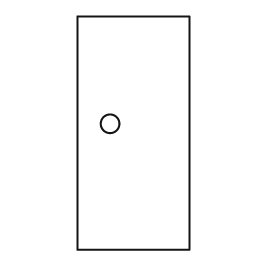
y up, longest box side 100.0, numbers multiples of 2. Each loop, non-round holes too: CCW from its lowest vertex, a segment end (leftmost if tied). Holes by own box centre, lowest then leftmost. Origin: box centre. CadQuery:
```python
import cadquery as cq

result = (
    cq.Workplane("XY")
    .moveTo(-24.0, -50.0)
    .lineTo(24.0, -50.0)
    .lineTo(24.0, 50.0)
    .lineTo(-24.0, 50.0)
    .close()
    .moveTo(-10.0, 4.0)
    .circle(4.0)
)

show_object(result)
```